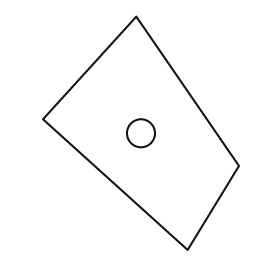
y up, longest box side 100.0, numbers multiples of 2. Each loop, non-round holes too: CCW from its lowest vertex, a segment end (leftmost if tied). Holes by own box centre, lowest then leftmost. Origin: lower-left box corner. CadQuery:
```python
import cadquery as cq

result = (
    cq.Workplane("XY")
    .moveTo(62.0, 0.0)
    .lineTo(84.0, 36.0)
    .lineTo(40.0, 100.0)
    .lineTo(0.0, 56.0)
    .close()
    .moveTo(42.0, 50.0)
    .circle(6.0)
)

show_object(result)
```